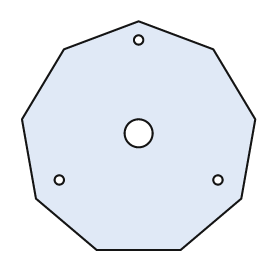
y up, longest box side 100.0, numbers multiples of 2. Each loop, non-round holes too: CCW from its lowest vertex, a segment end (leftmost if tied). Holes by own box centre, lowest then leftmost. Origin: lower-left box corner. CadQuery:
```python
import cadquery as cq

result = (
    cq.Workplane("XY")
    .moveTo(32.0, 0.0)
    .lineTo(68.0, 0.0)
    .lineTo(94.0, 22.0)
    .lineTo(100.0, 56.0)
    .lineTo(82.0, 86.0)
    .lineTo(50.0, 98.0)
    .lineTo(18.0, 86.0)
    .lineTo(0.0, 56.0)
    .lineTo(6.0, 22.0)
    .close()
    .moveTo(16.0, 30.0)
    .circle(2.0)
    .moveTo(84.0, 30.0)
    .circle(2.0)
    .moveTo(50.0, 50.0)
    .circle(6.0)
    .moveTo(50.0, 90.0)
    .circle(2.0)
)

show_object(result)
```